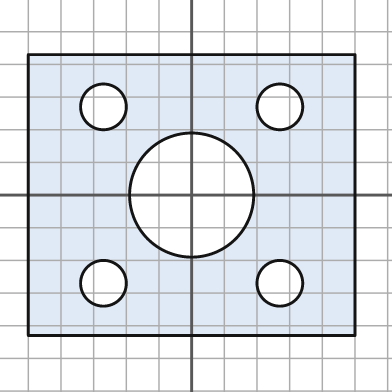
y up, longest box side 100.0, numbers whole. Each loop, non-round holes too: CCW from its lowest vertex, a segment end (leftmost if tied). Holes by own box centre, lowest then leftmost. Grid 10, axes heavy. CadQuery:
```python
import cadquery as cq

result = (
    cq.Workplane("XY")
    .moveTo(-50.0, -43.0)
    .lineTo(50.0, -43.0)
    .lineTo(50.0, 43.0)
    .lineTo(-50.0, 43.0)
    .close()
    .moveTo(-27.0, -27.0)
    .circle(7.0)
    .moveTo(27.0, -27.0)
    .circle(7.0)
    .moveTo(0.0, 0.0)
    .circle(19.0)
    .moveTo(-27.0, 27.0)
    .circle(7.0)
    .moveTo(27.0, 27.0)
    .circle(7.0)
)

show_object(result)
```